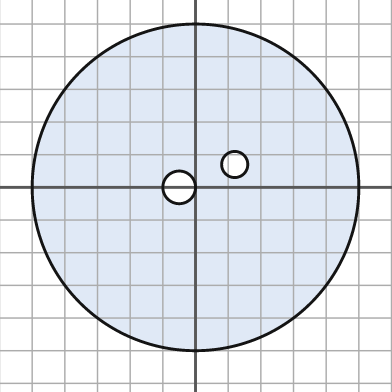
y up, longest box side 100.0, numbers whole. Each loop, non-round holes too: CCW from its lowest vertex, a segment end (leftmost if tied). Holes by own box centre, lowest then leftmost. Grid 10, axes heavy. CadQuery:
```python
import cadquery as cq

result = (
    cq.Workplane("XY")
    .moveTo(0.0, 0.0)
    .circle(50.0)
    .moveTo(-5.0, 0.0)
    .circle(5.0)
    .moveTo(12.0, 7.0)
    .circle(4.0)
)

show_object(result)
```